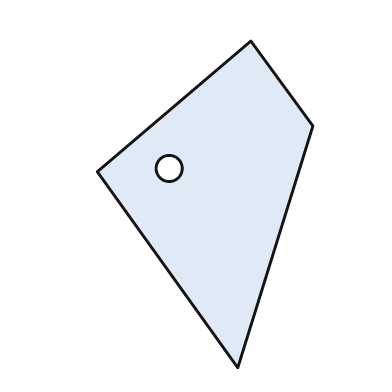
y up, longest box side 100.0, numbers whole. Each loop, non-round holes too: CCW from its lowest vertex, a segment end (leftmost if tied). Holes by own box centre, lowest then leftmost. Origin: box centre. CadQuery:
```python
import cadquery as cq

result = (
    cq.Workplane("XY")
    .moveTo(10.0, -50.0)
    .lineTo(33.0, 24.0)
    .lineTo(14.0, 50.0)
    .lineTo(-33.0, 10.0)
    .close()
    .moveTo(-11.0, 11.0)
    .circle(4.0)
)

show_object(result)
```